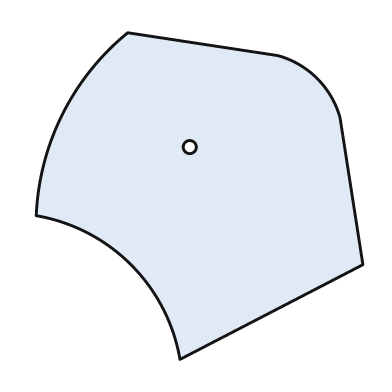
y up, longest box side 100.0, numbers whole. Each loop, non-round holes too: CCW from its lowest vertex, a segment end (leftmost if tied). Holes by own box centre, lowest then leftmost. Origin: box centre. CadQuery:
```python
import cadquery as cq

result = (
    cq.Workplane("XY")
    .moveTo(-6.0, -50.0)
    .lineTo(50.0, -21.0)
    .lineTo(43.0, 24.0)
    .threePointArc((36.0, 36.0), (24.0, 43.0))
    .lineTo(-22.0, 50.0)
    .threePointArc((-42.0, 25.0), (-50.0, -6.0))
    .threePointArc((-21.0, -21.0), (-6.0, -50.0))
    .close()
    .moveTo(-3.0, 15.0)
    .circle(2.0)
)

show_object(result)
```